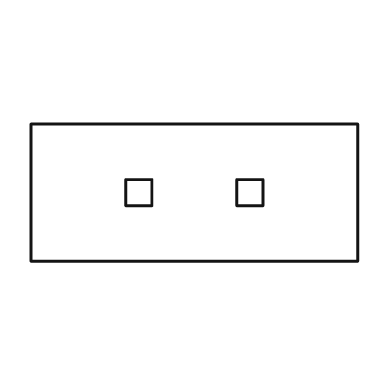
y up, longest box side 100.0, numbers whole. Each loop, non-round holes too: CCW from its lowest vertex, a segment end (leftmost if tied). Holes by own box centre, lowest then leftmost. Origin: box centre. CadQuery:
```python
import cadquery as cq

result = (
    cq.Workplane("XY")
    .moveTo(-50.0, -21.0)
    .lineTo(50.0, -21.0)
    .lineTo(50.0, 21.0)
    .lineTo(-50.0, 21.0)
    .close()
    .moveTo(-21.0, -4.0)
    .lineTo(-13.0, -4.0)
    .lineTo(-13.0, 4.0)
    .lineTo(-21.0, 4.0)
    .close()
    .moveTo(13.0, -4.0)
    .lineTo(21.0, -4.0)
    .lineTo(21.0, 4.0)
    .lineTo(13.0, 4.0)
    .close()
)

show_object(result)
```